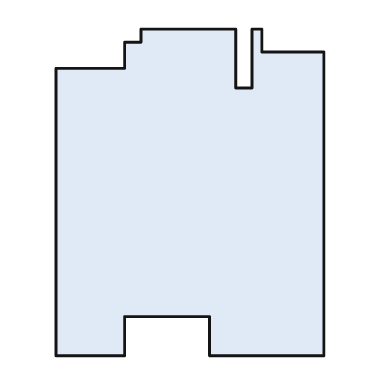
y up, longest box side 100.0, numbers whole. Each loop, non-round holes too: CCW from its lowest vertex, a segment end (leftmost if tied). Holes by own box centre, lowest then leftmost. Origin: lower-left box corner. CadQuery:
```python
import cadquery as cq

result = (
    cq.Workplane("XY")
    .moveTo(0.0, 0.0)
    .lineTo(21.0, 0.0)
    .lineTo(21.0, 12.0)
    .lineTo(47.0, 12.0)
    .lineTo(47.0, 0.0)
    .lineTo(82.0, 0.0)
    .lineTo(82.0, 93.0)
    .lineTo(63.0, 93.0)
    .lineTo(63.0, 100.0)
    .lineTo(60.0, 100.0)
    .lineTo(60.0, 82.0)
    .lineTo(55.0, 82.0)
    .lineTo(55.0, 100.0)
    .lineTo(26.0, 100.0)
    .lineTo(26.0, 96.0)
    .lineTo(21.0, 96.0)
    .lineTo(21.0, 88.0)
    .lineTo(0.0, 88.0)
    .close()
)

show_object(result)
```